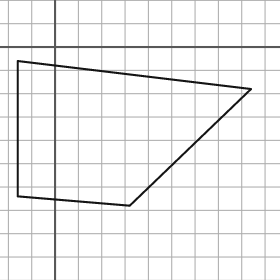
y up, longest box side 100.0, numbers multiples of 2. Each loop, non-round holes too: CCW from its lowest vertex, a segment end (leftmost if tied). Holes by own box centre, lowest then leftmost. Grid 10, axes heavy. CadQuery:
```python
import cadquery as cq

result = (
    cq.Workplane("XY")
    .moveTo(32.0, -68.0)
    .lineTo(84.0, -18.0)
    .lineTo(-16.0, -6.0)
    .lineTo(-16.0, -64.0)
    .close()
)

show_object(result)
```